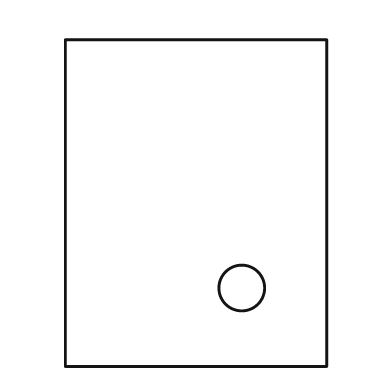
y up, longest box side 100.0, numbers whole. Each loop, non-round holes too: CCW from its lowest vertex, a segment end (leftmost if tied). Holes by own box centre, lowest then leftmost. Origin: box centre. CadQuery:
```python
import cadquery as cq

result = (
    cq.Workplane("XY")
    .moveTo(-40.0, -50.0)
    .lineTo(40.0, -50.0)
    .lineTo(40.0, 50.0)
    .lineTo(-40.0, 50.0)
    .close()
    .moveTo(14.0, -26.0)
    .circle(7.0)
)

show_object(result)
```